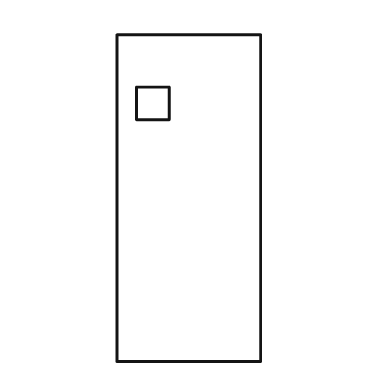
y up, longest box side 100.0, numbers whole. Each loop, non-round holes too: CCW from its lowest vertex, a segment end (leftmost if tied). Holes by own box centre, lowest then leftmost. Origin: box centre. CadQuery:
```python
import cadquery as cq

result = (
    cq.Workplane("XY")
    .moveTo(-22.0, -50.0)
    .lineTo(22.0, -50.0)
    .lineTo(22.0, 50.0)
    .lineTo(-22.0, 50.0)
    .close()
    .moveTo(-16.0, 24.0)
    .lineTo(-6.0, 24.0)
    .lineTo(-6.0, 34.0)
    .lineTo(-16.0, 34.0)
    .close()
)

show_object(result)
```